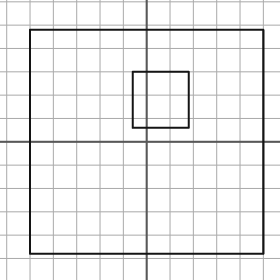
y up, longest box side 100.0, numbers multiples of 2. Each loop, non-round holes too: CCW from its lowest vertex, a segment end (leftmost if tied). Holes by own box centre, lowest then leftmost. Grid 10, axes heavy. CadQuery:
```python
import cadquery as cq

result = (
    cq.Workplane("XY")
    .moveTo(-50.0, -48.0)
    .lineTo(50.0, -48.0)
    .lineTo(50.0, 48.0)
    .lineTo(-50.0, 48.0)
    .close()
    .moveTo(-6.0, 6.0)
    .lineTo(18.0, 6.0)
    .lineTo(18.0, 30.0)
    .lineTo(-6.0, 30.0)
    .close()
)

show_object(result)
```